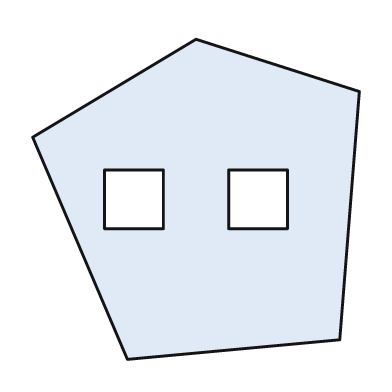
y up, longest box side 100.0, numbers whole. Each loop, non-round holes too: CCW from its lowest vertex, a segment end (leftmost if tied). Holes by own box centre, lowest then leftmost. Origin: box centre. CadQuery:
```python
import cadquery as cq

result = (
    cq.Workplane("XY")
    .moveTo(-21.0, -49.0)
    .lineTo(44.0, -43.0)
    .lineTo(50.0, 33.0)
    .lineTo(0.0, 49.0)
    .lineTo(-50.0, 19.0)
    .close()
    .moveTo(-28.0, -9.0)
    .lineTo(-10.0, -9.0)
    .lineTo(-10.0, 9.0)
    .lineTo(-28.0, 9.0)
    .close()
    .moveTo(10.0, -9.0)
    .lineTo(28.0, -9.0)
    .lineTo(28.0, 9.0)
    .lineTo(10.0, 9.0)
    .close()
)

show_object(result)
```